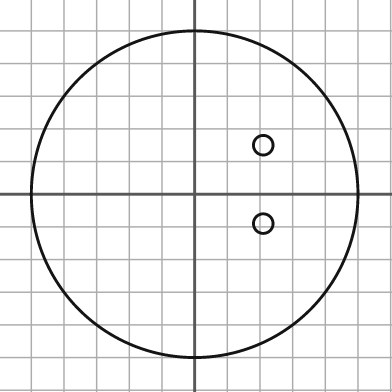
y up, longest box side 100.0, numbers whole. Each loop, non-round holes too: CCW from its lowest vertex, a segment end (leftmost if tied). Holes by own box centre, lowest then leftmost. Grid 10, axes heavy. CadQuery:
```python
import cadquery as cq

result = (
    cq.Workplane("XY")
    .moveTo(0.0, 0.0)
    .circle(50.0)
    .moveTo(21.0, -9.0)
    .circle(3.0)
    .moveTo(21.0, 15.0)
    .circle(3.0)
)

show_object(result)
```